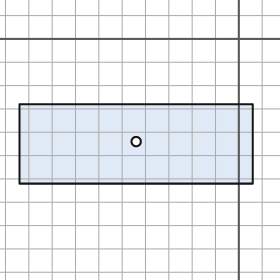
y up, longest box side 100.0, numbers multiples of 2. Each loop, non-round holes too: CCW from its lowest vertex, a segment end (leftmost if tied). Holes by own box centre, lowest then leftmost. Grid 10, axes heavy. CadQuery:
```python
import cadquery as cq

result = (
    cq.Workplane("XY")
    .moveTo(-94.0, -62.0)
    .lineTo(6.0, -62.0)
    .lineTo(6.0, -28.0)
    .lineTo(-94.0, -28.0)
    .close()
    .moveTo(-44.0, -44.0)
    .circle(2.0)
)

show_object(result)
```